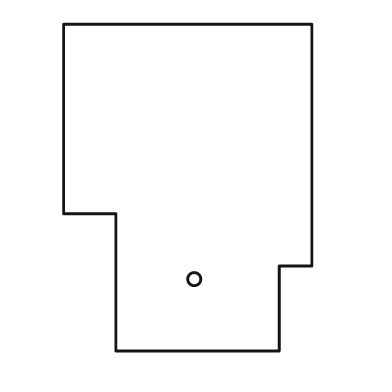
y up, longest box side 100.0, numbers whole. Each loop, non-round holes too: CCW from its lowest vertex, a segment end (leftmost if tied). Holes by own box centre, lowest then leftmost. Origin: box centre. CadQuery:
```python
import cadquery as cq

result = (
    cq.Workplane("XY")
    .moveTo(-22.0, -50.0)
    .lineTo(28.0, -50.0)
    .lineTo(28.0, -24.0)
    .lineTo(38.0, -24.0)
    .lineTo(38.0, 50.0)
    .lineTo(-38.0, 50.0)
    .lineTo(-38.0, -8.0)
    .lineTo(-22.0, -8.0)
    .close()
    .moveTo(2.0, -28.0)
    .circle(2.0)
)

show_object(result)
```